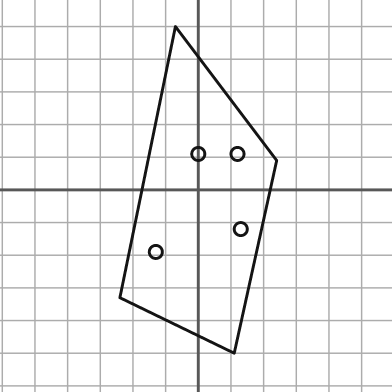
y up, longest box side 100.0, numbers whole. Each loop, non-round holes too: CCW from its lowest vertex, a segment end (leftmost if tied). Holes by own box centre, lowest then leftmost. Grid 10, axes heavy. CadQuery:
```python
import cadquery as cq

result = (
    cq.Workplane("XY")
    .moveTo(11.0, -50.0)
    .lineTo(24.0, 9.0)
    .lineTo(-7.0, 50.0)
    .lineTo(-24.0, -33.0)
    .close()
    .moveTo(-13.0, -19.0)
    .circle(2.0)
    .moveTo(13.0, -12.0)
    .circle(2.0)
    .moveTo(0.0, 11.0)
    .circle(2.0)
    .moveTo(12.0, 11.0)
    .circle(2.0)
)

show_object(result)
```